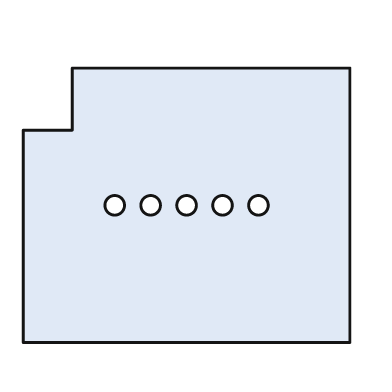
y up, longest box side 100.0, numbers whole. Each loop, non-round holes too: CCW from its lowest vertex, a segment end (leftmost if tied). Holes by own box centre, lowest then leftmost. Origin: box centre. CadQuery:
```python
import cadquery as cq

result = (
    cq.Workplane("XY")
    .moveTo(-50.0, -42.0)
    .lineTo(50.0, -42.0)
    .lineTo(50.0, 42.0)
    .lineTo(-35.0, 42.0)
    .lineTo(-35.0, 23.0)
    .lineTo(-50.0, 23.0)
    .close()
    .moveTo(-22.0, 0.0)
    .circle(3.0)
    .moveTo(-11.0, 0.0)
    .circle(3.0)
    .moveTo(0.0, 0.0)
    .circle(3.0)
    .moveTo(11.0, 0.0)
    .circle(3.0)
    .moveTo(22.0, 0.0)
    .circle(3.0)
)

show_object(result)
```